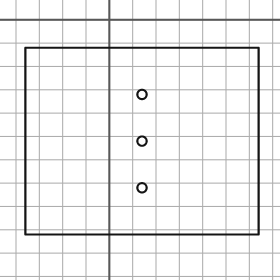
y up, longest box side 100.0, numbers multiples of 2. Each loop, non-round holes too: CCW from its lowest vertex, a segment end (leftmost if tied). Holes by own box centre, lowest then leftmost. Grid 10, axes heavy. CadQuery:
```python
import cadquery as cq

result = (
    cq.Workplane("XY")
    .moveTo(-36.0, -92.0)
    .lineTo(64.0, -92.0)
    .lineTo(64.0, -12.0)
    .lineTo(-36.0, -12.0)
    .close()
    .moveTo(14.0, -72.0)
    .circle(2.0)
    .moveTo(14.0, -52.0)
    .circle(2.0)
    .moveTo(14.0, -32.0)
    .circle(2.0)
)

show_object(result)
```